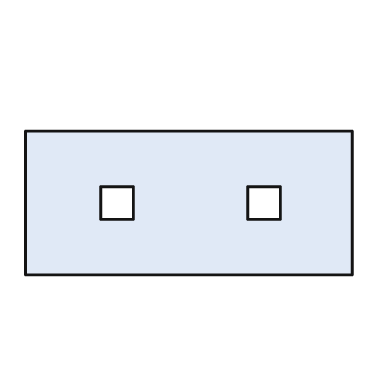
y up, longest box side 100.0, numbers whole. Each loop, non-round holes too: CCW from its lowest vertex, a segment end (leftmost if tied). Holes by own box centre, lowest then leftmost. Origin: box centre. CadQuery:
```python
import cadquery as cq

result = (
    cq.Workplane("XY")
    .moveTo(-50.0, -22.0)
    .lineTo(50.0, -22.0)
    .lineTo(50.0, 22.0)
    .lineTo(-50.0, 22.0)
    .close()
    .moveTo(-27.0, -5.0)
    .lineTo(-17.0, -5.0)
    .lineTo(-17.0, 5.0)
    .lineTo(-27.0, 5.0)
    .close()
    .moveTo(18.0, -5.0)
    .lineTo(28.0, -5.0)
    .lineTo(28.0, 5.0)
    .lineTo(18.0, 5.0)
    .close()
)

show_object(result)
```